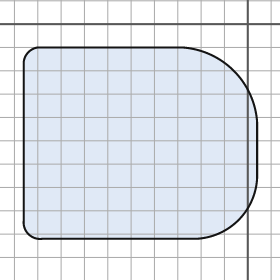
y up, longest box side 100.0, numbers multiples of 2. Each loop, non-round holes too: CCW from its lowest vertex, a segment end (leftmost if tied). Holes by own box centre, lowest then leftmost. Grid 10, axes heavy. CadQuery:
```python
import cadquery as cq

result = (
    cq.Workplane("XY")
    .moveTo(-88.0, -92.0)
    .lineTo(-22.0, -92.0)
    .threePointArc((-4.0, -84.0), (4.0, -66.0))
    .lineTo(4.0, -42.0)
    .threePointArc((-6.0, -20.0), (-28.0, -10.0))
    .lineTo(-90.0, -10.0)
    .threePointArc((-94.0, -12.0), (-96.0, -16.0))
    .lineTo(-96.0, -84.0)
    .threePointArc((-94.0, -90.0), (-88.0, -92.0))
    .close()
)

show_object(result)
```